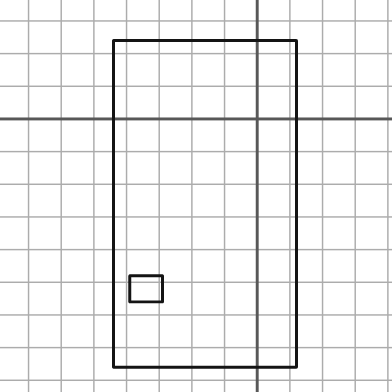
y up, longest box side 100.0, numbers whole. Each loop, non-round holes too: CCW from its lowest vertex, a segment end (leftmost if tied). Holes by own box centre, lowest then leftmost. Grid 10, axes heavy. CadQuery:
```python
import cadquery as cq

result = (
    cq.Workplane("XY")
    .moveTo(-44.0, -76.0)
    .lineTo(12.0, -76.0)
    .lineTo(12.0, 24.0)
    .lineTo(-44.0, 24.0)
    .close()
    .moveTo(-39.0, -56.0)
    .lineTo(-29.0, -56.0)
    .lineTo(-29.0, -48.0)
    .lineTo(-39.0, -48.0)
    .close()
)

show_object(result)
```